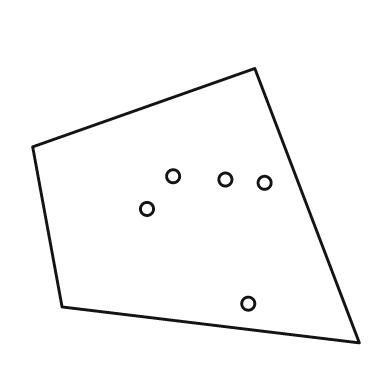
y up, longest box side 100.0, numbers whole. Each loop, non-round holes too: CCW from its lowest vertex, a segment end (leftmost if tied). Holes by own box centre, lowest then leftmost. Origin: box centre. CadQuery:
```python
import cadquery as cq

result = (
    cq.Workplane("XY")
    .moveTo(50.0, -42.0)
    .lineTo(18.0, 42.0)
    .lineTo(-50.0, 18.0)
    .lineTo(-41.0, -31.0)
    .close()
    .moveTo(16.0, -30.0)
    .circle(2.0)
    .moveTo(-15.0, -1.0)
    .circle(2.0)
    .moveTo(21.0, 7.0)
    .circle(2.0)
    .moveTo(9.0, 8.0)
    .circle(2.0)
    .moveTo(-7.0, 9.0)
    .circle(2.0)
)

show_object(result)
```